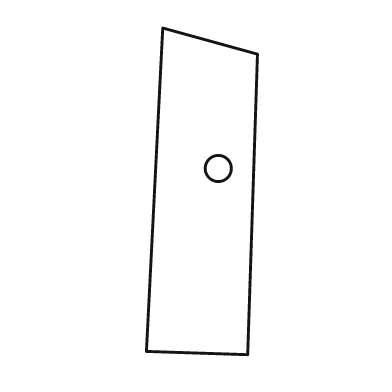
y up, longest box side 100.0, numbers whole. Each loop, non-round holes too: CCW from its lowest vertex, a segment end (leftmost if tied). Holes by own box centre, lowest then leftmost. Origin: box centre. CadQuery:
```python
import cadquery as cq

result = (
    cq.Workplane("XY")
    .moveTo(14.0, -50.0)
    .lineTo(17.0, 42.0)
    .lineTo(-12.0, 50.0)
    .lineTo(-17.0, -49.0)
    .close()
    .moveTo(5.0, 7.0)
    .circle(4.0)
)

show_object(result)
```